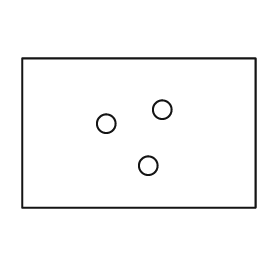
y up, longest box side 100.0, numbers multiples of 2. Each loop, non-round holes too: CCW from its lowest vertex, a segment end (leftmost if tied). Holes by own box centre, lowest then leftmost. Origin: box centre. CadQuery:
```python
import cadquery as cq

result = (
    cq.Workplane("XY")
    .moveTo(-50.0, -32.0)
    .lineTo(50.0, -32.0)
    .lineTo(50.0, 32.0)
    .lineTo(-50.0, 32.0)
    .close()
    .moveTo(4.0, -14.0)
    .circle(4.0)
    .moveTo(-14.0, 4.0)
    .circle(4.0)
    .moveTo(10.0, 10.0)
    .circle(4.0)
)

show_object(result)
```